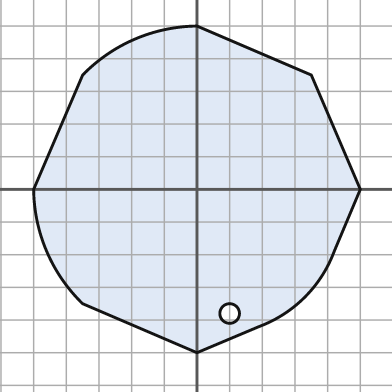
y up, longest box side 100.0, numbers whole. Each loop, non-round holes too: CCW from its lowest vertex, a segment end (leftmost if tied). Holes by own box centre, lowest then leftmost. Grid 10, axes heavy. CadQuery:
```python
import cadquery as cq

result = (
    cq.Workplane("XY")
    .moveTo(0.0, -50.0)
    .lineTo(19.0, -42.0)
    .threePointArc((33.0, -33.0), (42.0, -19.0))
    .lineTo(50.0, 0.0)
    .lineTo(35.0, 35.0)
    .lineTo(0.0, 50.0)
    .threePointArc((-19.0, 46.0), (-35.0, 35.0))
    .lineTo(-50.0, 0.0)
    .threePointArc((-46.0, -19.0), (-35.0, -35.0))
    .close()
    .moveTo(10.0, -38.0)
    .circle(3.0)
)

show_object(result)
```